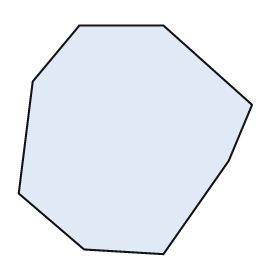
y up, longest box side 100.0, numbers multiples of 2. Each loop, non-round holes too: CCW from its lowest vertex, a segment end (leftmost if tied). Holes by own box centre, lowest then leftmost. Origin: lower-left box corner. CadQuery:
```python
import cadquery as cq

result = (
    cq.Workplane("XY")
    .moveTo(62.0, 0.0)
    .lineTo(90.0, 40.0)
    .lineTo(100.0, 64.0)
    .lineTo(62.0, 98.0)
    .lineTo(26.0, 98.0)
    .lineTo(6.0, 74.0)
    .lineTo(0.0, 26.0)
    .lineTo(28.0, 2.0)
    .close()
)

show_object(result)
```